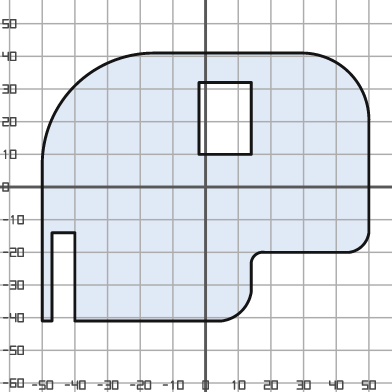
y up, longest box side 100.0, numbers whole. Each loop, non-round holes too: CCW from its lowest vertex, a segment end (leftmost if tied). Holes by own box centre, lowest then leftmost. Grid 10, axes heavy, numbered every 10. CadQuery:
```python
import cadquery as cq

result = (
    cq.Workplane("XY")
    .moveTo(-50.0, -41.0)
    .lineTo(-47.0, -41.0)
    .lineTo(-47.0, -14.0)
    .lineTo(-40.0, -14.0)
    .lineTo(-40.0, -41.0)
    .lineTo(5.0, -41.0)
    .threePointArc((11.0, -38.0), (14.0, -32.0))
    .lineTo(14.0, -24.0)
    .threePointArc((15.0, -21.0), (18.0, -20.0))
    .lineTo(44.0, -20.0)
    .threePointArc((48.0, -18.0), (50.0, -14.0))
    .lineTo(50.0, 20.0)
    .threePointArc((44.0, 35.0), (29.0, 41.0))
    .lineTo(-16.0, 41.0)
    .threePointArc((-40.0, 31.0), (-50.0, 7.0))
    .close()
    .moveTo(-2.0, 10.0)
    .lineTo(14.0, 10.0)
    .lineTo(14.0, 32.0)
    .lineTo(-2.0, 32.0)
    .close()
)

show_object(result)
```